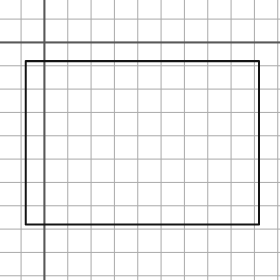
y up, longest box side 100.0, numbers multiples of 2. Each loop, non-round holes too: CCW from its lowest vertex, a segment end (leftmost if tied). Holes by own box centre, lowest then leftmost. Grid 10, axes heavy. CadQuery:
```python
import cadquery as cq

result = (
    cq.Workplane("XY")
    .moveTo(-8.0, -78.0)
    .lineTo(92.0, -78.0)
    .lineTo(92.0, -8.0)
    .lineTo(-8.0, -8.0)
    .close()
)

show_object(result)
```